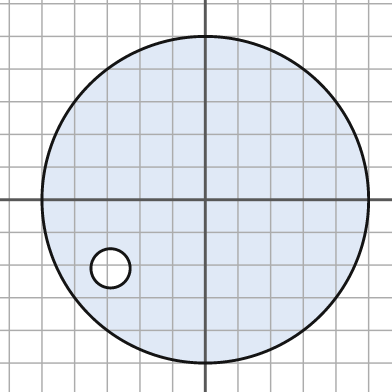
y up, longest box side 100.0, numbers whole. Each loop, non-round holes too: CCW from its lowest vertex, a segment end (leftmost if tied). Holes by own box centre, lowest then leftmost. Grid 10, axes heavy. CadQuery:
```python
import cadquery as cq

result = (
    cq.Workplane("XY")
    .moveTo(0.0, 0.0)
    .circle(50.0)
    .moveTo(-29.0, -21.0)
    .circle(6.0)
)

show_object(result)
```